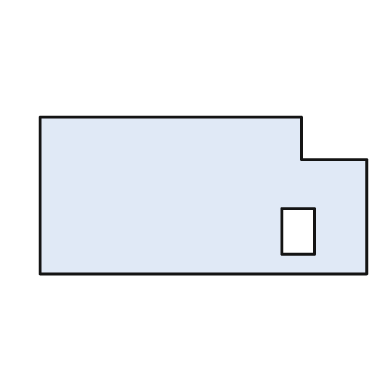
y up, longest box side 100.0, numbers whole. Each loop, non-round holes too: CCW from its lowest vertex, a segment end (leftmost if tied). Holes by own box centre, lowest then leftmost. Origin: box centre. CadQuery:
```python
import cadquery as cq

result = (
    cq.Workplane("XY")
    .moveTo(-50.0, -24.0)
    .lineTo(50.0, -24.0)
    .lineTo(50.0, 11.0)
    .lineTo(30.0, 11.0)
    .lineTo(30.0, 24.0)
    .lineTo(-50.0, 24.0)
    .close()
    .moveTo(24.0, -18.0)
    .lineTo(34.0, -18.0)
    .lineTo(34.0, -4.0)
    .lineTo(24.0, -4.0)
    .close()
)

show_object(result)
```